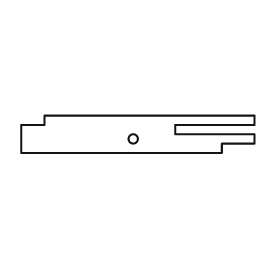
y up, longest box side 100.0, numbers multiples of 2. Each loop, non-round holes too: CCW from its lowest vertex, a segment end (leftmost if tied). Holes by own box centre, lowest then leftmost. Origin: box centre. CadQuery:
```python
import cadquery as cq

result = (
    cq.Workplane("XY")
    .moveTo(-50.0, -8.0)
    .lineTo(36.0, -8.0)
    .lineTo(36.0, -4.0)
    .lineTo(50.0, -4.0)
    .lineTo(50.0, 0.0)
    .lineTo(16.0, 0.0)
    .lineTo(16.0, 4.0)
    .lineTo(50.0, 4.0)
    .lineTo(50.0, 8.0)
    .lineTo(-40.0, 8.0)
    .lineTo(-40.0, 4.0)
    .lineTo(-50.0, 4.0)
    .close()
    .moveTo(-2.0, -2.0)
    .circle(2.0)
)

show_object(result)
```